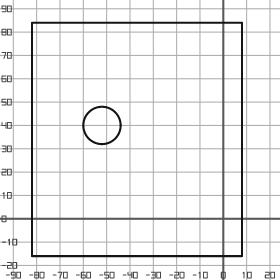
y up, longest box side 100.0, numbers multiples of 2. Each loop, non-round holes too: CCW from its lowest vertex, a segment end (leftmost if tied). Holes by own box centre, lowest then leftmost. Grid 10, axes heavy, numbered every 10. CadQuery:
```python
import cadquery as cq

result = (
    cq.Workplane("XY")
    .moveTo(-82.0, -16.0)
    .lineTo(8.0, -16.0)
    .lineTo(8.0, 84.0)
    .lineTo(-82.0, 84.0)
    .close()
    .moveTo(-52.0, 40.0)
    .circle(8.0)
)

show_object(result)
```